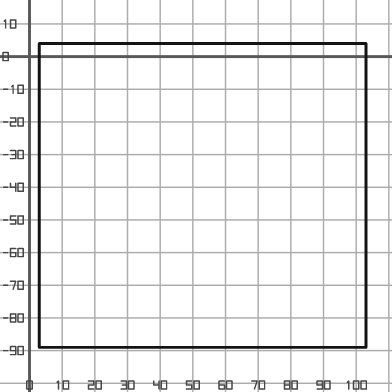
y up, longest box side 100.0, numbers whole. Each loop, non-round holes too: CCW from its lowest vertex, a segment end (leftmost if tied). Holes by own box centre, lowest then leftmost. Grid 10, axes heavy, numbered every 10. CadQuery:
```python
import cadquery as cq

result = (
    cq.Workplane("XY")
    .moveTo(3.0, -89.0)
    .lineTo(103.0, -89.0)
    .lineTo(103.0, 4.0)
    .lineTo(3.0, 4.0)
    .close()
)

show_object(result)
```